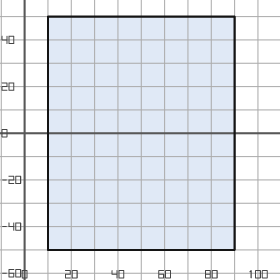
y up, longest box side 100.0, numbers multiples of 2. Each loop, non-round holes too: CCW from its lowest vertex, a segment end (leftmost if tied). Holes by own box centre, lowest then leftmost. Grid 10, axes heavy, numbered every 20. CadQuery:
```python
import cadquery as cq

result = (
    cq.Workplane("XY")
    .moveTo(10.0, -50.0)
    .lineTo(90.0, -50.0)
    .lineTo(90.0, 50.0)
    .lineTo(10.0, 50.0)
    .close()
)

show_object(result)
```